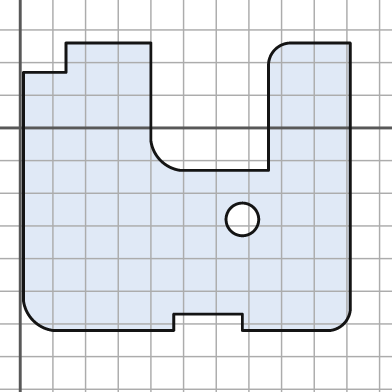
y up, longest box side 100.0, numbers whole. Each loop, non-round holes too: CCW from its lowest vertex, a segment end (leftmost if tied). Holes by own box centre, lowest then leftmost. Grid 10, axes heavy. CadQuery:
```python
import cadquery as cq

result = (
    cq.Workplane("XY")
    .moveTo(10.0, -62.0)
    .lineTo(47.0, -62.0)
    .lineTo(47.0, -57.0)
    .lineTo(68.0, -57.0)
    .lineTo(68.0, -62.0)
    .lineTo(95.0, -62.0)
    .threePointArc((99.0, -60.0), (101.0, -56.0))
    .lineTo(101.0, 26.0)
    .lineTo(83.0, 26.0)
    .threePointArc((78.0, 24.0), (76.0, 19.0))
    .lineTo(76.0, -13.0)
    .lineTo(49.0, -13.0)
    .threePointArc((43.0, -10.0), (40.0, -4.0))
    .lineTo(40.0, 26.0)
    .lineTo(14.0, 26.0)
    .lineTo(14.0, 17.0)
    .lineTo(1.0, 17.0)
    .lineTo(1.0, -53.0)
    .threePointArc((4.0, -59.0), (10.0, -62.0))
    .close()
    .moveTo(68.0, -28.0)
    .circle(5.0)
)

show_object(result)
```